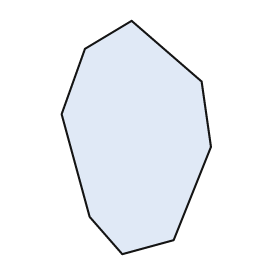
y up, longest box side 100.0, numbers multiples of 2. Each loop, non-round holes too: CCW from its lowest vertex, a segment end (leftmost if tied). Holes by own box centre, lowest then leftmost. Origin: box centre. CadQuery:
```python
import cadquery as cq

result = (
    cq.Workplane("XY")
    .moveTo(-6.0, -50.0)
    .lineTo(16.0, -44.0)
    .lineTo(32.0, -4.0)
    .lineTo(28.0, 24.0)
    .lineTo(-2.0, 50.0)
    .lineTo(-22.0, 38.0)
    .lineTo(-32.0, 10.0)
    .lineTo(-20.0, -34.0)
    .close()
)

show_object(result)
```